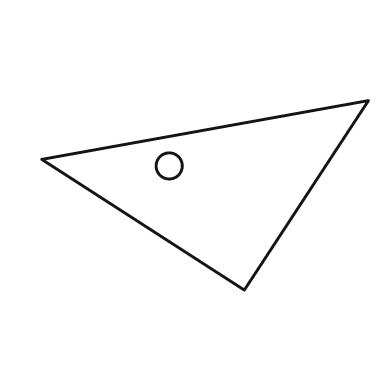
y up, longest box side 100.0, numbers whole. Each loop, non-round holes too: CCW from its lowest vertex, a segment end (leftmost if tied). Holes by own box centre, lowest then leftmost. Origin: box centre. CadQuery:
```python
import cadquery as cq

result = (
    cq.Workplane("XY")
    .moveTo(12.0, -29.0)
    .lineTo(50.0, 29.0)
    .lineTo(-50.0, 11.0)
    .close()
    .moveTo(-11.0, 9.0)
    .circle(4.0)
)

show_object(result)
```